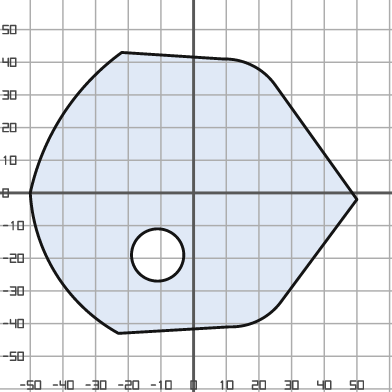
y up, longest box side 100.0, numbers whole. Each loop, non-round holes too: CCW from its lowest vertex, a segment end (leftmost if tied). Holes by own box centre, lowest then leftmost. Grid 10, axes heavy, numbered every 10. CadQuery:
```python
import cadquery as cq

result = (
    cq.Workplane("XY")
    .moveTo(-23.0, -43.0)
    .lineTo(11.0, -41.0)
    .threePointArc((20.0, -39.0), (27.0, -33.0))
    .lineTo(50.0, -2.0)
    .lineTo(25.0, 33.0)
    .threePointArc((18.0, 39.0), (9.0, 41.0))
    .lineTo(-22.0, 43.0)
    .threePointArc((-40.0, 24.0), (-50.0, 0.0))
    .threePointArc((-42.0, -25.0), (-23.0, -43.0))
    .close()
    .moveTo(-11.0, -19.0)
    .circle(8.0)
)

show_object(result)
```